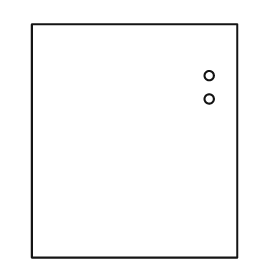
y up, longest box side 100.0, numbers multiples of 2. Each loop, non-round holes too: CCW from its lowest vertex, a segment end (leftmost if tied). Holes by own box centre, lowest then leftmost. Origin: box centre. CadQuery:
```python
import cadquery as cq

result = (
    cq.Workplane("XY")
    .moveTo(-44.0, -50.0)
    .lineTo(44.0, -50.0)
    .lineTo(44.0, 50.0)
    .lineTo(-44.0, 50.0)
    .close()
    .moveTo(32.0, 18.0)
    .circle(2.0)
    .moveTo(32.0, 28.0)
    .circle(2.0)
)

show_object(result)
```